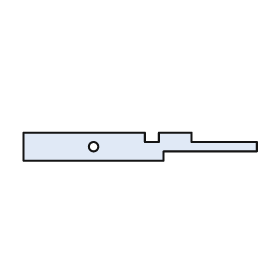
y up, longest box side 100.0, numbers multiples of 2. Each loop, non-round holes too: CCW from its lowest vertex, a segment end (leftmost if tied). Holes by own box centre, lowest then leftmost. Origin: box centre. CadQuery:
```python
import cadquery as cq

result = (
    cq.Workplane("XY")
    .moveTo(-50.0, -6.0)
    .lineTo(10.0, -6.0)
    .lineTo(10.0, -2.0)
    .lineTo(50.0, -2.0)
    .lineTo(50.0, 2.0)
    .lineTo(22.0, 2.0)
    .lineTo(22.0, 6.0)
    .lineTo(8.0, 6.0)
    .lineTo(8.0, 2.0)
    .lineTo(2.0, 2.0)
    .lineTo(2.0, 6.0)
    .lineTo(-50.0, 6.0)
    .close()
    .moveTo(-20.0, 0.0)
    .circle(2.0)
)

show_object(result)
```